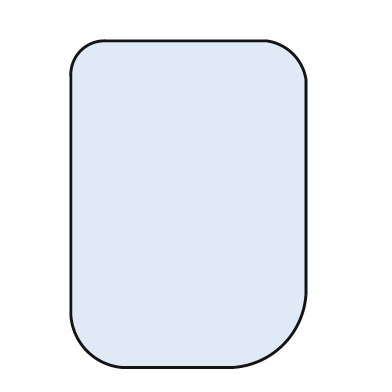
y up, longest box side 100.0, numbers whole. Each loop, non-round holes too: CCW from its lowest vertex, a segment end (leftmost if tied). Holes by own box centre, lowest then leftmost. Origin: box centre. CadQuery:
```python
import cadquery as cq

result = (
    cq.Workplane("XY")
    .moveTo(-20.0, -50.0)
    .lineTo(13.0, -50.0)
    .threePointArc((29.0, -43.0), (36.0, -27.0))
    .lineTo(36.0, 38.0)
    .threePointArc((32.0, 46.0), (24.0, 50.0))
    .lineTo(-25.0, 50.0)
    .threePointArc((-33.0, 47.0), (-36.0, 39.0))
    .lineTo(-36.0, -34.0)
    .threePointArc((-31.0, -45.0), (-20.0, -50.0))
    .close()
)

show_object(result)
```